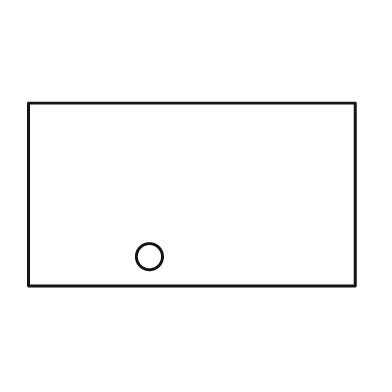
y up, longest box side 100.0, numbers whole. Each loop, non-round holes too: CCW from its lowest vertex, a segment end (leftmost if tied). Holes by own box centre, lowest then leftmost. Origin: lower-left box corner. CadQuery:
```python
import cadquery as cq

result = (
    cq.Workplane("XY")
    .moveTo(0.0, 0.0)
    .lineTo(100.0, 0.0)
    .lineTo(100.0, 56.0)
    .lineTo(0.0, 56.0)
    .close()
    .moveTo(37.0, 9.0)
    .circle(4.0)
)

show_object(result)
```